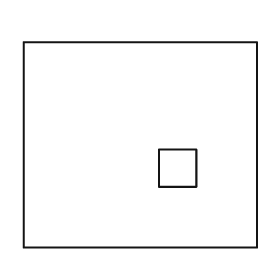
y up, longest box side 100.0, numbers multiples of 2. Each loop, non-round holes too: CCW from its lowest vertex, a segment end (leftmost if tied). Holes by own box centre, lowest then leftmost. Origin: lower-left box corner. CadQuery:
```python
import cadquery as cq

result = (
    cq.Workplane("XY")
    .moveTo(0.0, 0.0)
    .lineTo(100.0, 0.0)
    .lineTo(100.0, 88.0)
    .lineTo(0.0, 88.0)
    .close()
    .moveTo(58.0, 26.0)
    .lineTo(74.0, 26.0)
    .lineTo(74.0, 42.0)
    .lineTo(58.0, 42.0)
    .close()
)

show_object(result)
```